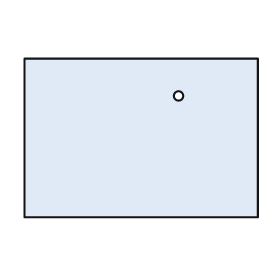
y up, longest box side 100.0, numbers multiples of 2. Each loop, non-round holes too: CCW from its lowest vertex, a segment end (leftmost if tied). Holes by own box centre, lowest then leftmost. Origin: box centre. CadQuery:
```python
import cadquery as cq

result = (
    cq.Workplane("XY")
    .moveTo(-50.0, -34.0)
    .lineTo(50.0, -34.0)
    .lineTo(50.0, 34.0)
    .lineTo(-50.0, 34.0)
    .close()
    .moveTo(16.0, 18.0)
    .circle(2.0)
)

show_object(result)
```